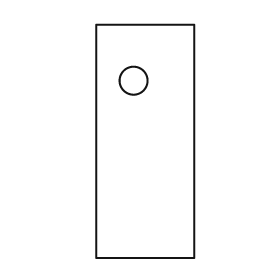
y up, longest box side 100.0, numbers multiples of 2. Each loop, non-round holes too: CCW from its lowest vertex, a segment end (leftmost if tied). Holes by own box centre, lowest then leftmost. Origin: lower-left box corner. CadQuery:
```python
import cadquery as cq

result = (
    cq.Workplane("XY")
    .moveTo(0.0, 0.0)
    .lineTo(42.0, 0.0)
    .lineTo(42.0, 100.0)
    .lineTo(0.0, 100.0)
    .close()
    .moveTo(16.0, 76.0)
    .circle(6.0)
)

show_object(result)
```